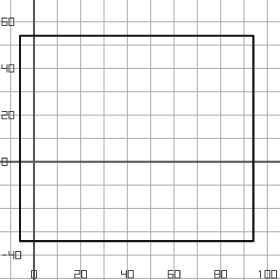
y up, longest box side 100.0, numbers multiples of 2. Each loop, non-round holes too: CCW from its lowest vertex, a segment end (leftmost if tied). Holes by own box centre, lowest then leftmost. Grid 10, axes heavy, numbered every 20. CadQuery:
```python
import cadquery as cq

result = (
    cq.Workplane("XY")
    .moveTo(-6.0, -34.0)
    .lineTo(94.0, -34.0)
    .lineTo(94.0, 54.0)
    .lineTo(-6.0, 54.0)
    .close()
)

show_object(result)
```